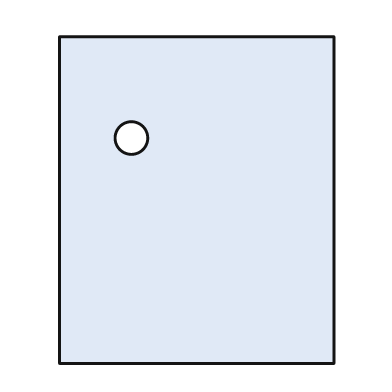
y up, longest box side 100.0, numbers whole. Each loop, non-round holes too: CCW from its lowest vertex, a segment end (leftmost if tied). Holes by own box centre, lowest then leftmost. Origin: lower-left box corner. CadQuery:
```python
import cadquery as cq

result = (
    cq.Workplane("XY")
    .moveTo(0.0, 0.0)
    .lineTo(84.0, 0.0)
    .lineTo(84.0, 100.0)
    .lineTo(0.0, 100.0)
    .close()
    .moveTo(22.0, 69.0)
    .circle(5.0)
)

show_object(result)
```